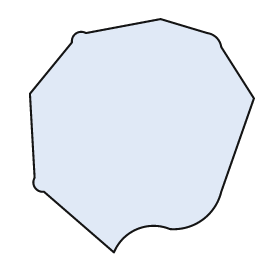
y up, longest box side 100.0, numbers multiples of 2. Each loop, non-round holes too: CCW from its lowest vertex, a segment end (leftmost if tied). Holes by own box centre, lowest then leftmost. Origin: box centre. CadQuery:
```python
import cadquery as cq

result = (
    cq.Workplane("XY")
    .moveTo(-12.0, -50.0)
    .threePointArc((-2.0, -40.0), (12.0, -40.0))
    .threePointArc((26.0, -36.0), (34.0, -24.0))
    .lineTo(48.0, 16.0)
    .lineTo(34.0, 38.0)
    .threePointArc((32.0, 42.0), (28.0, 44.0))
    .lineTo(8.0, 50.0)
    .lineTo(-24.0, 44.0)
    .threePointArc((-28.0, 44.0), (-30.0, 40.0))
    .lineTo(-48.0, 18.0)
    .lineTo(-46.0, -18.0)
    .threePointArc((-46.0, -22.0), (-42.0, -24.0))
    .close()
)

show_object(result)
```